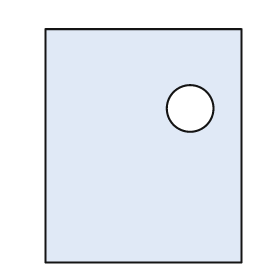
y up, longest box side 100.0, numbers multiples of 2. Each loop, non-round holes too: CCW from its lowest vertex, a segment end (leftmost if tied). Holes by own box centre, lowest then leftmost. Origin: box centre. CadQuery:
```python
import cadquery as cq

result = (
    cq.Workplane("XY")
    .moveTo(-42.0, -50.0)
    .lineTo(42.0, -50.0)
    .lineTo(42.0, 50.0)
    .lineTo(-42.0, 50.0)
    .close()
    .moveTo(20.0, 16.0)
    .circle(10.0)
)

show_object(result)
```